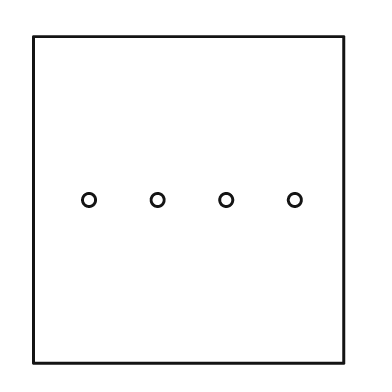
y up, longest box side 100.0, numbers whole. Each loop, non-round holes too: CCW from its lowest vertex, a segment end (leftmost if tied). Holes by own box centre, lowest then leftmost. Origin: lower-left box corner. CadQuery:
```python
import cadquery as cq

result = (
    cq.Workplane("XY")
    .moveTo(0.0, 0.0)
    .lineTo(95.0, 0.0)
    .lineTo(95.0, 100.0)
    .lineTo(0.0, 100.0)
    .close()
    .moveTo(17.0, 50.0)
    .circle(2.0)
    .moveTo(38.0, 50.0)
    .circle(2.0)
    .moveTo(59.0, 50.0)
    .circle(2.0)
    .moveTo(80.0, 50.0)
    .circle(2.0)
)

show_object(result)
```